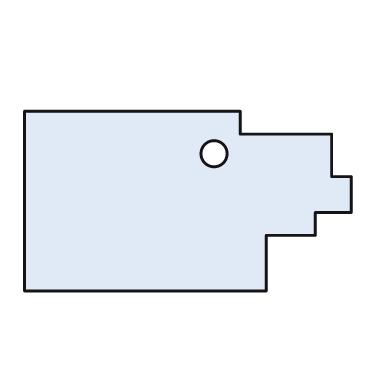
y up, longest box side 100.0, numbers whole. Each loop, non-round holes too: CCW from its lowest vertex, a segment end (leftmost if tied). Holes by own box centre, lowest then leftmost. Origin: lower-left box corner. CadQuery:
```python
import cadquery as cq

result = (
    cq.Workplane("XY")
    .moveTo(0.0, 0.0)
    .lineTo(74.0, 0.0)
    .lineTo(74.0, 17.0)
    .lineTo(89.0, 17.0)
    .lineTo(89.0, 24.0)
    .lineTo(100.0, 24.0)
    .lineTo(100.0, 35.0)
    .lineTo(94.0, 35.0)
    .lineTo(94.0, 48.0)
    .lineTo(66.0, 48.0)
    .lineTo(66.0, 55.0)
    .lineTo(0.0, 55.0)
    .close()
    .moveTo(58.0, 42.0)
    .circle(4.0)
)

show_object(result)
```